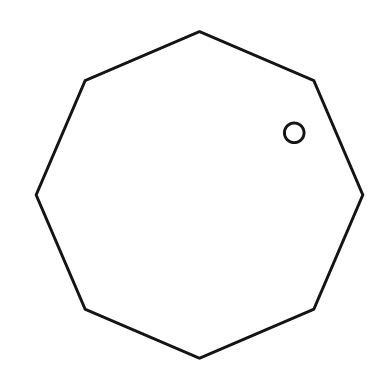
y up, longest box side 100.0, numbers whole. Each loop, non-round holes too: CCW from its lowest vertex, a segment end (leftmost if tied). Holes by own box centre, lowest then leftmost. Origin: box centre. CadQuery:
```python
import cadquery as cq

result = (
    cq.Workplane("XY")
    .moveTo(0.0, -50.0)
    .lineTo(35.0, -35.0)
    .lineTo(50.0, 0.0)
    .lineTo(35.0, 35.0)
    .lineTo(0.0, 50.0)
    .lineTo(-35.0, 35.0)
    .lineTo(-50.0, 0.0)
    .lineTo(-35.0, -35.0)
    .close()
    .moveTo(29.0, 19.0)
    .circle(3.0)
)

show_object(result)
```